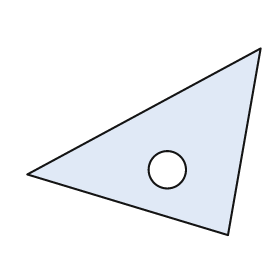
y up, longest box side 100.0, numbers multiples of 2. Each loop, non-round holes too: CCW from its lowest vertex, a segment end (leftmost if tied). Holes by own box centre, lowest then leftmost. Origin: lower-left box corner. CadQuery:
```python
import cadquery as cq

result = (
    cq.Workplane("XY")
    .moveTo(86.0, 0.0)
    .lineTo(100.0, 80.0)
    .lineTo(0.0, 26.0)
    .close()
    .moveTo(60.0, 28.0)
    .circle(8.0)
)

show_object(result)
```